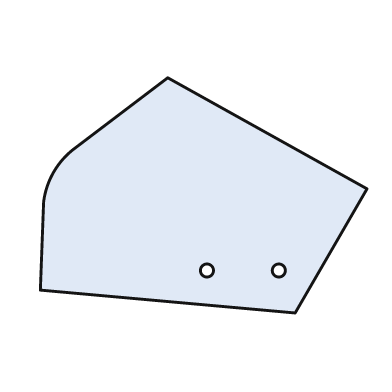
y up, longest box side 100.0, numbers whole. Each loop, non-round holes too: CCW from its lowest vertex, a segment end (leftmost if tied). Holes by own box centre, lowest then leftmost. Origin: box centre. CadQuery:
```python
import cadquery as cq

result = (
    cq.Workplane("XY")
    .moveTo(28.0, -36.0)
    .lineTo(50.0, 2.0)
    .lineTo(-11.0, 36.0)
    .lineTo(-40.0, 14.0)
    .threePointArc((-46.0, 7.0), (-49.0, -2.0))
    .lineTo(-50.0, -29.0)
    .close()
    .moveTo(1.0, -23.0)
    .circle(2.0)
    .moveTo(23.0, -23.0)
    .circle(2.0)
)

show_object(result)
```